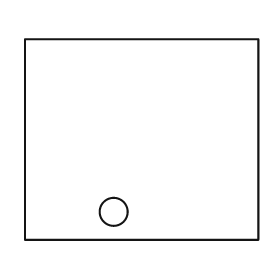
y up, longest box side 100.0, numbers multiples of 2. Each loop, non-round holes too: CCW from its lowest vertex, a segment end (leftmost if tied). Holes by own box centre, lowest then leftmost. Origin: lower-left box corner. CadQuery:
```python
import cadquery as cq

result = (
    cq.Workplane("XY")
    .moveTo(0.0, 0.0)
    .lineTo(100.0, 0.0)
    .lineTo(100.0, 86.0)
    .lineTo(0.0, 86.0)
    .close()
    .moveTo(38.0, 12.0)
    .circle(6.0)
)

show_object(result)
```